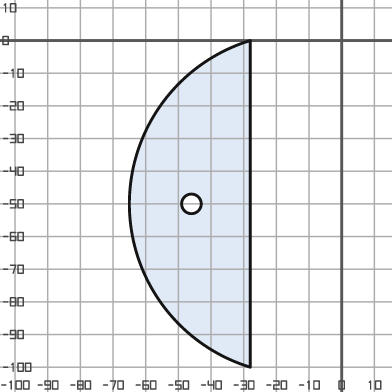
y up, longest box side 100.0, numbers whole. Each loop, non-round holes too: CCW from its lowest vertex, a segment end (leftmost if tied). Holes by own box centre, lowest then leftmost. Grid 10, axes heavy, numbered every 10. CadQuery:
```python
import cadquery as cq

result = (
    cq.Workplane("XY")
    .moveTo(-28.0, -100.0)
    .lineTo(-28.0, 0.0)
    .threePointArc((-65.0, -50.0), (-28.0, -100.0))
    .close()
    .moveTo(-46.0, -50.0)
    .circle(3.0)
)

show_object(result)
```